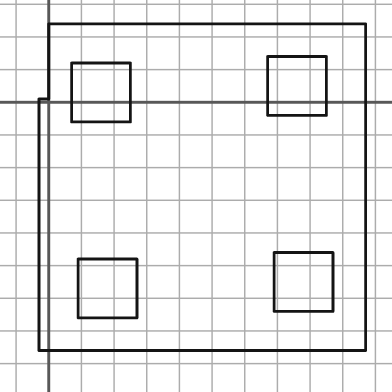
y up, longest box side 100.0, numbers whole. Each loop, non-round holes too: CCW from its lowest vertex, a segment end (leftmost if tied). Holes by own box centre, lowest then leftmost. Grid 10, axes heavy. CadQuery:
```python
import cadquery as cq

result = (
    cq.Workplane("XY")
    .moveTo(-3.0, -76.0)
    .lineTo(97.0, -76.0)
    .lineTo(97.0, 24.0)
    .lineTo(0.0, 24.0)
    .lineTo(0.0, 1.0)
    .lineTo(-3.0, 1.0)
    .close()
    .moveTo(9.0, -66.0)
    .lineTo(27.0, -66.0)
    .lineTo(27.0, -48.0)
    .lineTo(9.0, -48.0)
    .close()
    .moveTo(69.0, -64.0)
    .lineTo(87.0, -64.0)
    .lineTo(87.0, -46.0)
    .lineTo(69.0, -46.0)
    .close()
    .moveTo(7.0, -6.0)
    .lineTo(25.0, -6.0)
    .lineTo(25.0, 12.0)
    .lineTo(7.0, 12.0)
    .close()
    .moveTo(67.0, -4.0)
    .lineTo(85.0, -4.0)
    .lineTo(85.0, 14.0)
    .lineTo(67.0, 14.0)
    .close()
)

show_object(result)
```